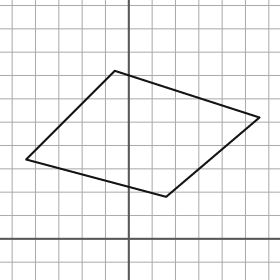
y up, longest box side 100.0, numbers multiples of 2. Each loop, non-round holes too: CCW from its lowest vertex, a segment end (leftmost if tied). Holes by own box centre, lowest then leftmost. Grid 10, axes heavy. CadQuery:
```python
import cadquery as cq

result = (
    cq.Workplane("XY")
    .moveTo(16.0, 18.0)
    .lineTo(56.0, 52.0)
    .lineTo(-6.0, 72.0)
    .lineTo(-44.0, 34.0)
    .close()
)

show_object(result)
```